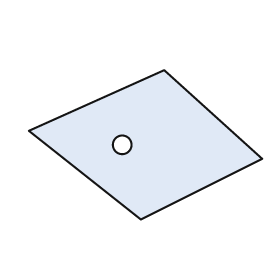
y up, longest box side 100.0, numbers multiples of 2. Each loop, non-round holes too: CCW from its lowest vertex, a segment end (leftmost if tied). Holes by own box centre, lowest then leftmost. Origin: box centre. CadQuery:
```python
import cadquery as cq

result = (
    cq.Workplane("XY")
    .moveTo(-2.0, -32.0)
    .lineTo(50.0, -6.0)
    .lineTo(8.0, 32.0)
    .lineTo(-50.0, 6.0)
    .close()
    .moveTo(-10.0, 0.0)
    .circle(4.0)
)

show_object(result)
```